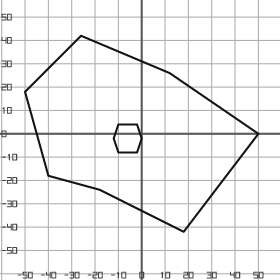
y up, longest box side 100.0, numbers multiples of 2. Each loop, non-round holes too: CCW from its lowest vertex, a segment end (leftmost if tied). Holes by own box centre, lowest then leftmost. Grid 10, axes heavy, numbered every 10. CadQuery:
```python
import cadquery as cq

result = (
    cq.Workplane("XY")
    .moveTo(18.0, -42.0)
    .lineTo(50.0, 0.0)
    .lineTo(12.0, 26.0)
    .lineTo(-26.0, 42.0)
    .lineTo(-50.0, 18.0)
    .lineTo(-40.0, -18.0)
    .lineTo(-18.0, -24.0)
    .close()
    .moveTo(-10.0, -8.0)
    .lineTo(-2.0, -8.0)
    .lineTo(0.0, -2.0)
    .lineTo(-2.0, 4.0)
    .lineTo(-10.0, 4.0)
    .lineTo(-12.0, -2.0)
    .close()
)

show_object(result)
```